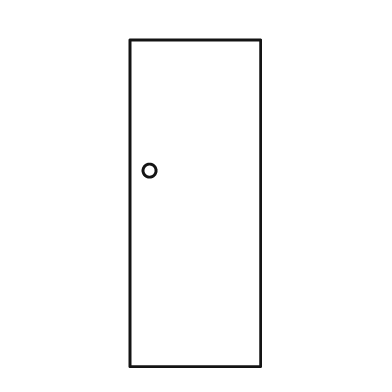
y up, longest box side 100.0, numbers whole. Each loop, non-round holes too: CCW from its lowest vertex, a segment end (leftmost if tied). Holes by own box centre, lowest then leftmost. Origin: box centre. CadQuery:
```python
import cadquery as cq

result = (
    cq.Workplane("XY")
    .moveTo(-20.0, -50.0)
    .lineTo(20.0, -50.0)
    .lineTo(20.0, 50.0)
    .lineTo(-20.0, 50.0)
    .close()
    .moveTo(-14.0, 10.0)
    .circle(2.0)
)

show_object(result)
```